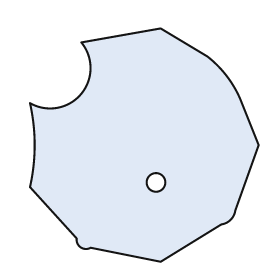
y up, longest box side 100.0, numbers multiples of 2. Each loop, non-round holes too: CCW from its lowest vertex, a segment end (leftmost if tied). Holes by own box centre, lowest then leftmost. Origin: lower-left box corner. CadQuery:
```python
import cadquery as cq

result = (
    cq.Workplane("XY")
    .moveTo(56.0, 0.0)
    .lineTo(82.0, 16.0)
    .threePointArc((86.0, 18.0), (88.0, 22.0))
    .lineTo(98.0, 50.0)
    .lineTo(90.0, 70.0)
    .threePointArc((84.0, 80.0), (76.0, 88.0))
    .lineTo(56.0, 100.0)
    .lineTo(22.0, 94.0)
    .threePointArc((22.0, 72.0), (0.0, 68.0))
    .threePointArc((2.0, 50.0), (0.0, 32.0))
    .lineTo(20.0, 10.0)
    .threePointArc((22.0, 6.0), (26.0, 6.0))
    .close()
    .moveTo(54.0, 34.0)
    .circle(4.0)
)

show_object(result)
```